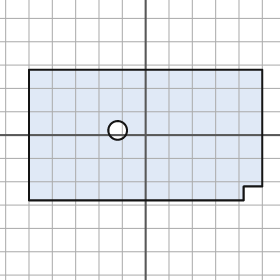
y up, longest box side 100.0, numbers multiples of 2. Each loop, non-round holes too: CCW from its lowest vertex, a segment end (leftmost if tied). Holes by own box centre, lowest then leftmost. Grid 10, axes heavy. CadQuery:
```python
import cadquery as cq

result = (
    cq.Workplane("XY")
    .moveTo(-50.0, -28.0)
    .lineTo(42.0, -28.0)
    .lineTo(42.0, -22.0)
    .lineTo(50.0, -22.0)
    .lineTo(50.0, 28.0)
    .lineTo(-50.0, 28.0)
    .close()
    .moveTo(-12.0, 2.0)
    .circle(4.0)
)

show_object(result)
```